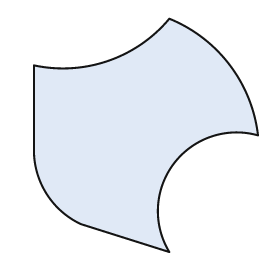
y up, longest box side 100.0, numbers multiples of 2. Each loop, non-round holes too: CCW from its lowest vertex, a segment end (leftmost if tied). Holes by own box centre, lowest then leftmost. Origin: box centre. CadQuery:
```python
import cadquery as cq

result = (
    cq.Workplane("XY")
    .moveTo(10.0, -50.0)
    .threePointArc((12.0, -12.0), (48.0, 0.0))
    .threePointArc((36.0, 30.0), (10.0, 50.0))
    .threePointArc((-16.0, 32.0), (-48.0, 30.0))
    .lineTo(-48.0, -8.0)
    .threePointArc((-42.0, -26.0), (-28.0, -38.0))
    .close()
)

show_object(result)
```